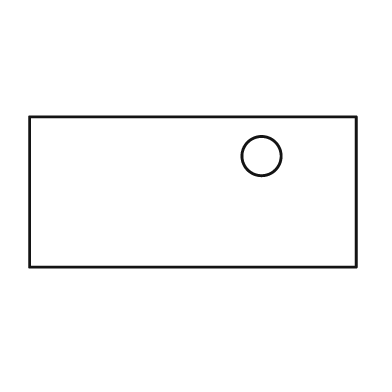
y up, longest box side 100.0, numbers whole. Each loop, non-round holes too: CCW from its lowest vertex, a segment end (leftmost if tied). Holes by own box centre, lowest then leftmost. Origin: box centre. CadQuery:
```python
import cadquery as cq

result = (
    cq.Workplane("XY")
    .moveTo(-50.0, -23.0)
    .lineTo(50.0, -23.0)
    .lineTo(50.0, 23.0)
    .lineTo(-50.0, 23.0)
    .close()
    .moveTo(21.0, 11.0)
    .circle(6.0)
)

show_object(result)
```